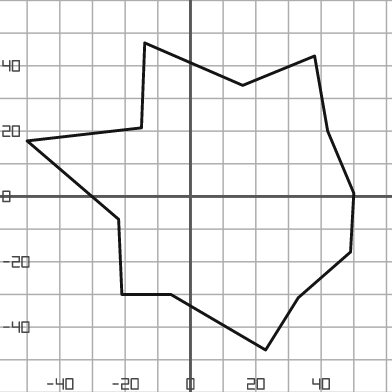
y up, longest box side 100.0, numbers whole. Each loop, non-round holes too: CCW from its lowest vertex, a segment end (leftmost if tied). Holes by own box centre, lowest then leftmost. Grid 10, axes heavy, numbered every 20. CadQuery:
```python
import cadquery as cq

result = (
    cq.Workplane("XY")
    .moveTo(23.0, -47.0)
    .lineTo(33.0, -31.0)
    .lineTo(49.0, -17.0)
    .lineTo(50.0, 1.0)
    .lineTo(42.0, 20.0)
    .lineTo(38.0, 43.0)
    .lineTo(16.0, 34.0)
    .lineTo(-14.0, 47.0)
    .lineTo(-15.0, 21.0)
    .lineTo(-50.0, 17.0)
    .lineTo(-22.0, -7.0)
    .lineTo(-21.0, -30.0)
    .lineTo(-6.0, -30.0)
    .close()
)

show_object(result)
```